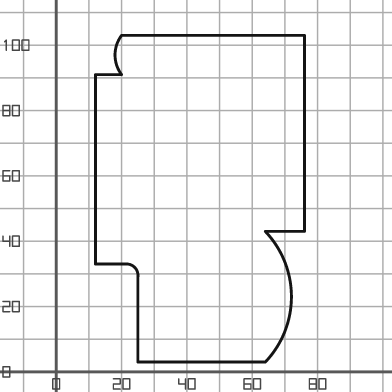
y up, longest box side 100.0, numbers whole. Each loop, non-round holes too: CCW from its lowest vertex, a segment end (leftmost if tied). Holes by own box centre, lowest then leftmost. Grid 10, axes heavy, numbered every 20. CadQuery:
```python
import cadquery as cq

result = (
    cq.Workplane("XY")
    .moveTo(25.0, 3.0)
    .lineTo(64.0, 3.0)
    .threePointArc((72.0, 23.0), (64.0, 43.0))
    .lineTo(76.0, 43.0)
    .lineTo(76.0, 103.0)
    .lineTo(20.0, 103.0)
    .threePointArc((18.0, 97.0), (20.0, 91.0))
    .lineTo(12.0, 91.0)
    .lineTo(12.0, 33.0)
    .lineTo(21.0, 33.0)
    .threePointArc((24.0, 32.0), (25.0, 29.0))
    .close()
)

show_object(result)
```